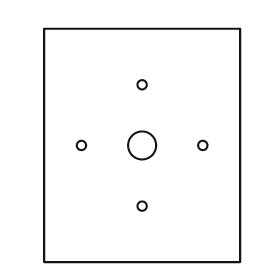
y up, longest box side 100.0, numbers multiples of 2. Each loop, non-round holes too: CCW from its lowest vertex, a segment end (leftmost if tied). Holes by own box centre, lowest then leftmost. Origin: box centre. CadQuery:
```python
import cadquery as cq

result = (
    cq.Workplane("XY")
    .moveTo(-42.0, -50.0)
    .lineTo(42.0, -50.0)
    .lineTo(42.0, 50.0)
    .lineTo(-42.0, 50.0)
    .close()
    .moveTo(0.0, -26.0)
    .circle(2.0)
    .moveTo(-26.0, 0.0)
    .circle(2.0)
    .moveTo(0.0, 0.0)
    .circle(6.0)
    .moveTo(26.0, 0.0)
    .circle(2.0)
    .moveTo(0.0, 26.0)
    .circle(2.0)
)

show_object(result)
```